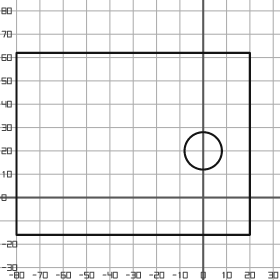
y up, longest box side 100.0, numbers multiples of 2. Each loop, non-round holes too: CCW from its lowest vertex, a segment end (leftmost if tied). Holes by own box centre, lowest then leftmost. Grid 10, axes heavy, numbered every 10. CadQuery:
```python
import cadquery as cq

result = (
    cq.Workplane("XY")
    .moveTo(-80.0, -16.0)
    .lineTo(20.0, -16.0)
    .lineTo(20.0, 62.0)
    .lineTo(-80.0, 62.0)
    .close()
    .moveTo(0.0, 20.0)
    .circle(8.0)
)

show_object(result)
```